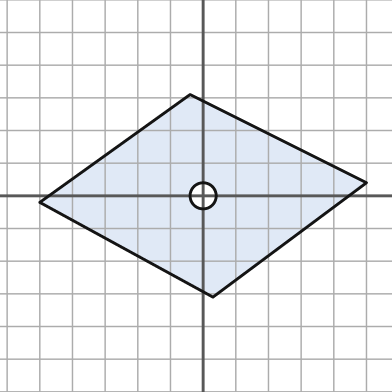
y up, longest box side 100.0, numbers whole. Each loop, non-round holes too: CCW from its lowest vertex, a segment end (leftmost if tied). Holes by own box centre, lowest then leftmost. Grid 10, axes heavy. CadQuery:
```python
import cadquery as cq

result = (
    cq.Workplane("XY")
    .moveTo(3.0, -31.0)
    .lineTo(50.0, 4.0)
    .lineTo(-4.0, 31.0)
    .lineTo(-50.0, -2.0)
    .close()
    .moveTo(0.0, 0.0)
    .circle(4.0)
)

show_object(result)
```